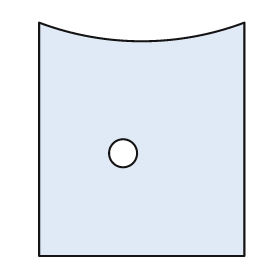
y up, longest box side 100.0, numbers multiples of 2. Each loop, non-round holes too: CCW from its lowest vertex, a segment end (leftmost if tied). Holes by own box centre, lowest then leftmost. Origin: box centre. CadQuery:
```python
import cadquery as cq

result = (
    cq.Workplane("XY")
    .moveTo(-44.0, -50.0)
    .lineTo(44.0, -50.0)
    .lineTo(44.0, 50.0)
    .threePointArc((0.0, 42.0), (-44.0, 50.0))
    .close()
    .moveTo(-8.0, -6.0)
    .circle(6.0)
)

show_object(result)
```